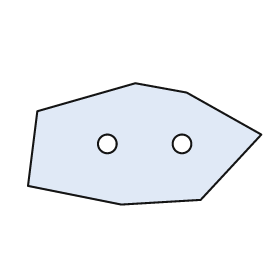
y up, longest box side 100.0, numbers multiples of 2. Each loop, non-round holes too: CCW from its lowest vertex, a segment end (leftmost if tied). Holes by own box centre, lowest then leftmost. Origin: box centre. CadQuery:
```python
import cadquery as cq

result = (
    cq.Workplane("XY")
    .moveTo(-10.0, -26.0)
    .lineTo(24.0, -24.0)
    .lineTo(50.0, 4.0)
    .lineTo(18.0, 22.0)
    .lineTo(-4.0, 26.0)
    .lineTo(-46.0, 14.0)
    .lineTo(-50.0, -18.0)
    .close()
    .moveTo(-16.0, 0.0)
    .circle(4.0)
    .moveTo(16.0, 0.0)
    .circle(4.0)
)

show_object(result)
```